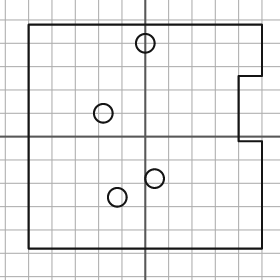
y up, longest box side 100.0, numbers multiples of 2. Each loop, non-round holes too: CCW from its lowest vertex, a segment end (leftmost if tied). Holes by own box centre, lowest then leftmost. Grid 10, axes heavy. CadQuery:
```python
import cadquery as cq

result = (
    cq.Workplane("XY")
    .moveTo(-50.0, -48.0)
    .lineTo(50.0, -48.0)
    .lineTo(50.0, -2.0)
    .lineTo(40.0, -2.0)
    .lineTo(40.0, 26.0)
    .lineTo(50.0, 26.0)
    .lineTo(50.0, 48.0)
    .lineTo(-50.0, 48.0)
    .close()
    .moveTo(-12.0, -26.0)
    .circle(4.0)
    .moveTo(4.0, -18.0)
    .circle(4.0)
    .moveTo(-18.0, 10.0)
    .circle(4.0)
    .moveTo(0.0, 40.0)
    .circle(4.0)
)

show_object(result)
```